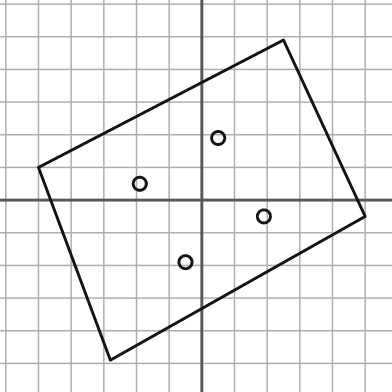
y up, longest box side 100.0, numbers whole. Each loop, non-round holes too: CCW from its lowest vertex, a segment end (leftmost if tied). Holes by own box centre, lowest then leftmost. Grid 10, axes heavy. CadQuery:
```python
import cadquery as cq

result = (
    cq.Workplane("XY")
    .moveTo(-28.0, -49.0)
    .lineTo(50.0, -5.0)
    .lineTo(25.0, 49.0)
    .lineTo(-50.0, 10.0)
    .close()
    .moveTo(-5.0, -19.0)
    .circle(2.0)
    .moveTo(19.0, -5.0)
    .circle(2.0)
    .moveTo(-19.0, 5.0)
    .circle(2.0)
    .moveTo(5.0, 19.0)
    .circle(2.0)
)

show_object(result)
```